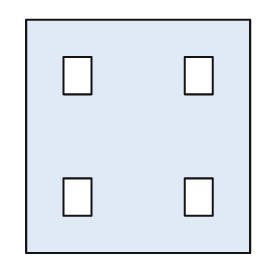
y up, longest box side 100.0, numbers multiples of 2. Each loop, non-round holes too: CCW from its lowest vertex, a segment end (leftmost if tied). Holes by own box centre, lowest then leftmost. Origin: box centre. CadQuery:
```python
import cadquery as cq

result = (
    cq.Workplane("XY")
    .moveTo(-48.0, -50.0)
    .lineTo(48.0, -50.0)
    .lineTo(48.0, 50.0)
    .lineTo(-48.0, 50.0)
    .close()
    .moveTo(-32.0, -34.0)
    .lineTo(-20.0, -34.0)
    .lineTo(-20.0, -18.0)
    .lineTo(-32.0, -18.0)
    .close()
    .moveTo(20.0, -34.0)
    .lineTo(32.0, -34.0)
    .lineTo(32.0, -18.0)
    .lineTo(20.0, -18.0)
    .close()
    .moveTo(-32.0, 18.0)
    .lineTo(-20.0, 18.0)
    .lineTo(-20.0, 34.0)
    .lineTo(-32.0, 34.0)
    .close()
    .moveTo(20.0, 18.0)
    .lineTo(32.0, 18.0)
    .lineTo(32.0, 34.0)
    .lineTo(20.0, 34.0)
    .close()
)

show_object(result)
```